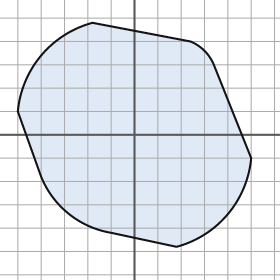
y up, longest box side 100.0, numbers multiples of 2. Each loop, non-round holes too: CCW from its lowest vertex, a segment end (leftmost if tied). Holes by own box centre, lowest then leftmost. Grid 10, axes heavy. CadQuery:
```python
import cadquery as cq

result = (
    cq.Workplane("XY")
    .moveTo(18.0, -48.0)
    .threePointArc((40.0, -34.0), (50.0, -10.0))
    .lineTo(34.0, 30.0)
    .threePointArc((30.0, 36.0), (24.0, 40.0))
    .lineTo(-18.0, 48.0)
    .threePointArc((-40.0, 34.0), (-50.0, 10.0))
    .lineTo(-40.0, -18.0)
    .threePointArc((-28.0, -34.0), (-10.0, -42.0))
    .close()
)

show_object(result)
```